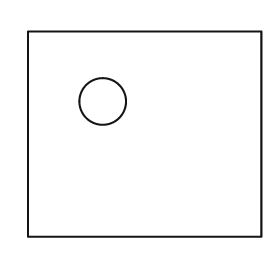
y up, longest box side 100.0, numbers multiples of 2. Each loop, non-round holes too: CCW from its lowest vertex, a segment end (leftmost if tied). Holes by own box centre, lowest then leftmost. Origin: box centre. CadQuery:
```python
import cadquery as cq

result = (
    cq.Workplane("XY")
    .moveTo(-50.0, -44.0)
    .lineTo(50.0, -44.0)
    .lineTo(50.0, 44.0)
    .lineTo(-50.0, 44.0)
    .close()
    .moveTo(-18.0, 14.0)
    .circle(10.0)
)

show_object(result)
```